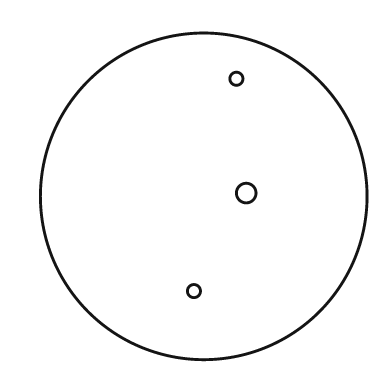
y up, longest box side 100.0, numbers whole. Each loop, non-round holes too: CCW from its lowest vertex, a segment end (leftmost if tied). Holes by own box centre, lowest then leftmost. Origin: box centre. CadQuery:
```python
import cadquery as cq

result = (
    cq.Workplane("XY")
    .moveTo(0.0, 0.0)
    .circle(50.0)
    .moveTo(-3.0, -29.0)
    .circle(2.0)
    .moveTo(13.0, 1.0)
    .circle(3.0)
    .moveTo(10.0, 36.0)
    .circle(2.0)
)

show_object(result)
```